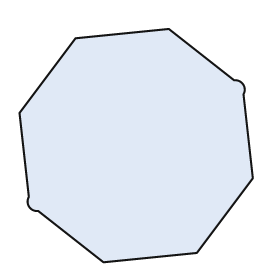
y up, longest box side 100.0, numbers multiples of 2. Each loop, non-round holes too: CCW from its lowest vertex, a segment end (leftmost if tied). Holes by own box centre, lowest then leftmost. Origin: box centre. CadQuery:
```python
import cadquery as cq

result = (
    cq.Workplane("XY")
    .moveTo(-14.0, -50.0)
    .lineTo(26.0, -46.0)
    .lineTo(50.0, -14.0)
    .lineTo(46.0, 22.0)
    .threePointArc((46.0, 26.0), (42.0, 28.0))
    .lineTo(14.0, 50.0)
    .lineTo(-26.0, 46.0)
    .lineTo(-50.0, 14.0)
    .lineTo(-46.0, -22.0)
    .threePointArc((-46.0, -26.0), (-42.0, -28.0))
    .close()
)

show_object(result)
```